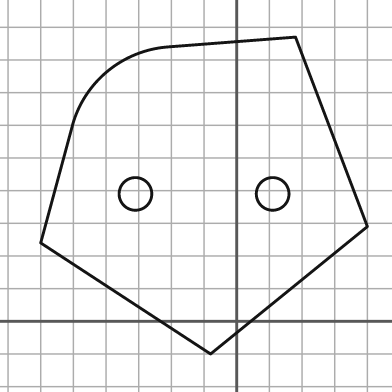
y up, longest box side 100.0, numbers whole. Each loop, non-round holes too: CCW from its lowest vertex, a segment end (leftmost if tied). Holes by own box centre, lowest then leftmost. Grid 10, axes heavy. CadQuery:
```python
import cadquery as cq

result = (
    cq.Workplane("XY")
    .moveTo(-8.0, -10.0)
    .lineTo(40.0, 29.0)
    .lineTo(18.0, 87.0)
    .lineTo(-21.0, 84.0)
    .threePointArc((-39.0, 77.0), (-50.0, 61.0))
    .lineTo(-60.0, 24.0)
    .close()
    .moveTo(-31.0, 39.0)
    .circle(5.0)
    .moveTo(11.0, 39.0)
    .circle(5.0)
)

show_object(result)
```